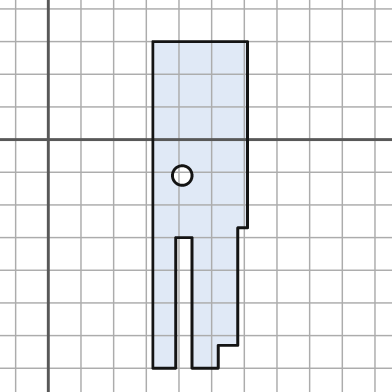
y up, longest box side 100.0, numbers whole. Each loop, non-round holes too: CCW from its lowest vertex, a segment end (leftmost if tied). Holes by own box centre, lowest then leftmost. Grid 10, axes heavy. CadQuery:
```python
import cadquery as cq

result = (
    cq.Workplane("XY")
    .moveTo(32.0, -70.0)
    .lineTo(39.0, -70.0)
    .lineTo(39.0, -30.0)
    .lineTo(44.0, -30.0)
    .lineTo(44.0, -70.0)
    .lineTo(52.0, -70.0)
    .lineTo(52.0, -63.0)
    .lineTo(58.0, -63.0)
    .lineTo(58.0, -27.0)
    .lineTo(61.0, -27.0)
    .lineTo(61.0, 30.0)
    .lineTo(32.0, 30.0)
    .close()
    .moveTo(41.0, -11.0)
    .circle(3.0)
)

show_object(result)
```